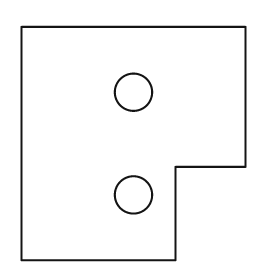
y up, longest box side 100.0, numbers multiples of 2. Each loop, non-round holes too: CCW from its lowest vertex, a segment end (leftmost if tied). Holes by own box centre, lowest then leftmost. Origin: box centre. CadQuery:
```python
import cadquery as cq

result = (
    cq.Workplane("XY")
    .moveTo(-48.0, -50.0)
    .lineTo(18.0, -50.0)
    .lineTo(18.0, -10.0)
    .lineTo(48.0, -10.0)
    .lineTo(48.0, 50.0)
    .lineTo(-48.0, 50.0)
    .close()
    .moveTo(0.0, -22.0)
    .circle(8.0)
    .moveTo(0.0, 22.0)
    .circle(8.0)
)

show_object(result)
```